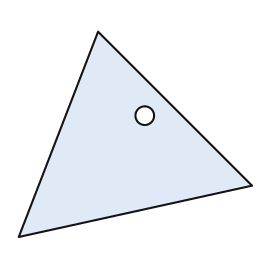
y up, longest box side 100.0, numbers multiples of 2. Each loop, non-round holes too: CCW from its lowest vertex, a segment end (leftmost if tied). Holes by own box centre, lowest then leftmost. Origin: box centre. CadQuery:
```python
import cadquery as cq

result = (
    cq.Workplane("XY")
    .moveTo(-50.0, -44.0)
    .lineTo(50.0, -22.0)
    .lineTo(-16.0, 44.0)
    .close()
    .moveTo(4.0, 8.0)
    .circle(4.0)
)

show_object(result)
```